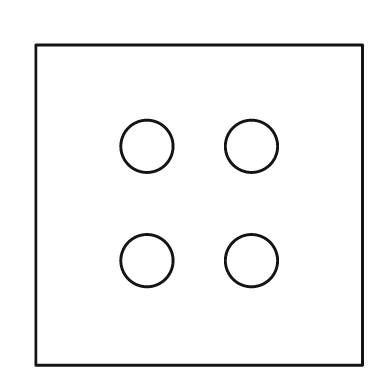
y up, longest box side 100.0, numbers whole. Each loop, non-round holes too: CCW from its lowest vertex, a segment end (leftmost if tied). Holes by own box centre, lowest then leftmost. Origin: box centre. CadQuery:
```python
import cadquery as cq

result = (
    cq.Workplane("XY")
    .moveTo(-50.0, -49.0)
    .lineTo(50.0, -49.0)
    .lineTo(50.0, 49.0)
    .lineTo(-50.0, 49.0)
    .close()
    .moveTo(-16.0, -17.0)
    .circle(8.0)
    .moveTo(16.0, -17.0)
    .circle(8.0)
    .moveTo(-16.0, 18.0)
    .circle(8.0)
    .moveTo(16.0, 18.0)
    .circle(8.0)
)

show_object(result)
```